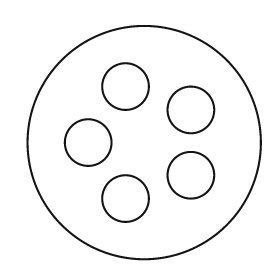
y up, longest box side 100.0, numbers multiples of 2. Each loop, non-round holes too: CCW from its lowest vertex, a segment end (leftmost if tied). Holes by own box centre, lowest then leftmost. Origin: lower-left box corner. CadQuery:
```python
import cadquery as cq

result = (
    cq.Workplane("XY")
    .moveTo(50.0, 50.0)
    .circle(50.0)
    .moveTo(42.0, 26.0)
    .circle(10.0)
    .moveTo(70.0, 36.0)
    .circle(10.0)
    .moveTo(26.0, 50.0)
    .circle(10.0)
    .moveTo(70.0, 64.0)
    .circle(10.0)
    .moveTo(42.0, 74.0)
    .circle(10.0)
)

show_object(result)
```